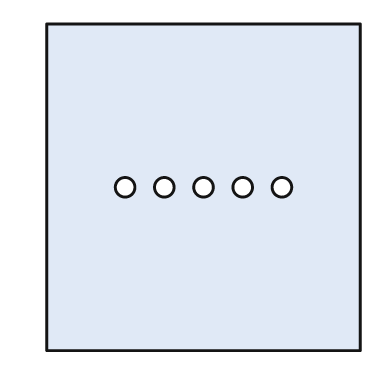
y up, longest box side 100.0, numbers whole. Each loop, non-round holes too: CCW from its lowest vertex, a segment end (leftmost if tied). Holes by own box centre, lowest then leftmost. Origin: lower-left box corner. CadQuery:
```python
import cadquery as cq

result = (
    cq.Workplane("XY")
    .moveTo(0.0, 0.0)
    .lineTo(96.0, 0.0)
    .lineTo(96.0, 100.0)
    .lineTo(0.0, 100.0)
    .close()
    .moveTo(24.0, 50.0)
    .circle(3.0)
    .moveTo(36.0, 50.0)
    .circle(3.0)
    .moveTo(48.0, 50.0)
    .circle(3.0)
    .moveTo(60.0, 50.0)
    .circle(3.0)
    .moveTo(72.0, 50.0)
    .circle(3.0)
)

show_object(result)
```